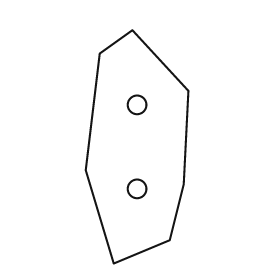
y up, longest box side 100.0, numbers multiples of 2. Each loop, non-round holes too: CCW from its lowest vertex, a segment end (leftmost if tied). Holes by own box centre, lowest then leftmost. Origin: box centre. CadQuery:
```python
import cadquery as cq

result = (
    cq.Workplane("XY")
    .moveTo(-10.0, -50.0)
    .lineTo(14.0, -40.0)
    .lineTo(20.0, -16.0)
    .lineTo(22.0, 24.0)
    .lineTo(-2.0, 50.0)
    .lineTo(-16.0, 40.0)
    .lineTo(-22.0, -10.0)
    .close()
    .moveTo(0.0, -18.0)
    .circle(4.0)
    .moveTo(0.0, 18.0)
    .circle(4.0)
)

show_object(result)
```